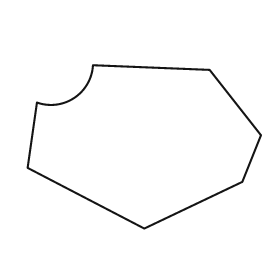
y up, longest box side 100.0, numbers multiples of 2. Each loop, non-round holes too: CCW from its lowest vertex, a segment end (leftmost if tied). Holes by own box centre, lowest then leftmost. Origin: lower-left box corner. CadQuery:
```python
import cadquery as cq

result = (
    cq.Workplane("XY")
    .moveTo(50.0, 0.0)
    .lineTo(92.0, 20.0)
    .lineTo(100.0, 40.0)
    .lineTo(78.0, 68.0)
    .lineTo(28.0, 70.0)
    .threePointArc((20.0, 56.0), (4.0, 54.0))
    .lineTo(0.0, 26.0)
    .close()
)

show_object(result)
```